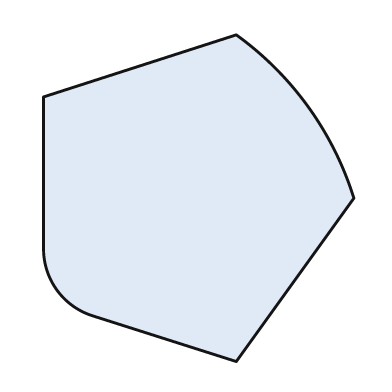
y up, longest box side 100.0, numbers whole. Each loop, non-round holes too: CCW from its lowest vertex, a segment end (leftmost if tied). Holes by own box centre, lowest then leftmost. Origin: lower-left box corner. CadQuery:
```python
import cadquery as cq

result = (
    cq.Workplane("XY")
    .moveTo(59.0, 0.0)
    .lineTo(95.0, 50.0)
    .threePointArc((81.0, 78.0), (59.0, 100.0))
    .lineTo(0.0, 81.0)
    .lineTo(0.0, 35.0)
    .threePointArc((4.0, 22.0), (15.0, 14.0))
    .close()
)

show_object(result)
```